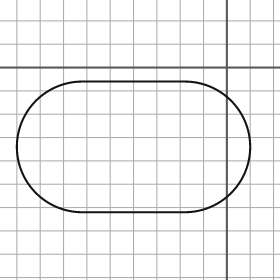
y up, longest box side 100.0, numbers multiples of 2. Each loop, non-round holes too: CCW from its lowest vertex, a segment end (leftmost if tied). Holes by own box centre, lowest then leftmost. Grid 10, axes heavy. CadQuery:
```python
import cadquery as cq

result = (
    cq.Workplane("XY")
    .moveTo(-62.0, -62.0)
    .lineTo(-18.0, -62.0)
    .threePointArc((10.0, -34.0), (-18.0, -6.0))
    .lineTo(-62.0, -6.0)
    .threePointArc((-90.0, -34.0), (-62.0, -62.0))
    .close()
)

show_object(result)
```